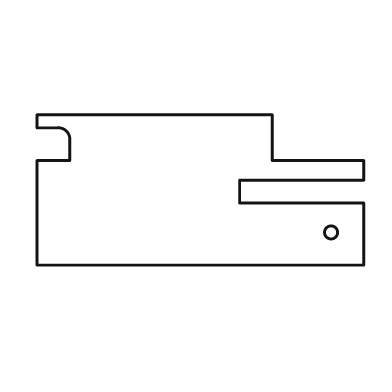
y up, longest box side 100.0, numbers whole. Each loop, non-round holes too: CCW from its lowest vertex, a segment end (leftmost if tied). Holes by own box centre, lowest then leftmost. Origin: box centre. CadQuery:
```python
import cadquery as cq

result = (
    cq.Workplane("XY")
    .moveTo(-50.0, -23.0)
    .lineTo(50.0, -23.0)
    .lineTo(50.0, -4.0)
    .lineTo(12.0, -4.0)
    .lineTo(12.0, 3.0)
    .lineTo(50.0, 3.0)
    .lineTo(50.0, 9.0)
    .lineTo(22.0, 9.0)
    .lineTo(22.0, 23.0)
    .lineTo(-50.0, 23.0)
    .lineTo(-50.0, 19.0)
    .lineTo(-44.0, 19.0)
    .threePointArc((-41.0, 18.0), (-40.0, 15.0))
    .lineTo(-40.0, 9.0)
    .lineTo(-50.0, 9.0)
    .close()
    .moveTo(40.0, -13.0)
    .circle(2.0)
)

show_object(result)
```